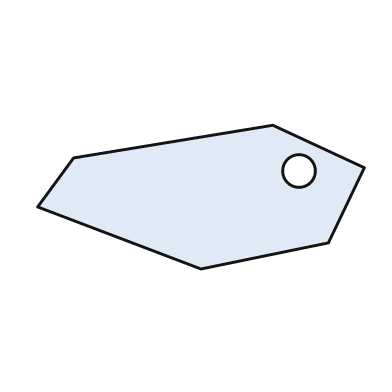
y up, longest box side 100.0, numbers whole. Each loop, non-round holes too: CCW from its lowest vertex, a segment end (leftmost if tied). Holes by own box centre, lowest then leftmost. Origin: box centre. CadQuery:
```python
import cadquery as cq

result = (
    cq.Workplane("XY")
    .moveTo(0.0, -22.0)
    .lineTo(39.0, -14.0)
    .lineTo(50.0, 9.0)
    .lineTo(22.0, 22.0)
    .lineTo(-39.0, 12.0)
    .lineTo(-50.0, -3.0)
    .close()
    .moveTo(30.0, 8.0)
    .circle(5.0)
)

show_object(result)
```